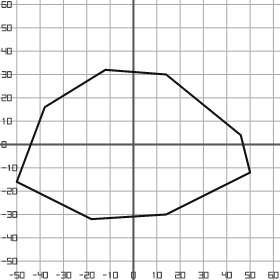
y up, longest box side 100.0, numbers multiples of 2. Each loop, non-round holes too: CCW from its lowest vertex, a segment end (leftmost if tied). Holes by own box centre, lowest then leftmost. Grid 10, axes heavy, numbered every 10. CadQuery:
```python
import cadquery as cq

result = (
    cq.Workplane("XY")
    .moveTo(-18.0, -32.0)
    .lineTo(14.0, -30.0)
    .lineTo(50.0, -12.0)
    .lineTo(46.0, 4.0)
    .lineTo(14.0, 30.0)
    .lineTo(-12.0, 32.0)
    .lineTo(-38.0, 16.0)
    .lineTo(-50.0, -16.0)
    .close()
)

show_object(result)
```